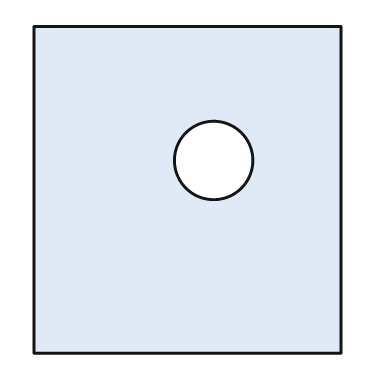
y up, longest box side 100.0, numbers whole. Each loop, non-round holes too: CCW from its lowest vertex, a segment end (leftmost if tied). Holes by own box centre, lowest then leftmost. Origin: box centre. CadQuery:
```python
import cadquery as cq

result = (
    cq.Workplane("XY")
    .moveTo(-47.0, -50.0)
    .lineTo(47.0, -50.0)
    .lineTo(47.0, 50.0)
    .lineTo(-47.0, 50.0)
    .close()
    .moveTo(8.0, 9.0)
    .circle(12.0)
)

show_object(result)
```